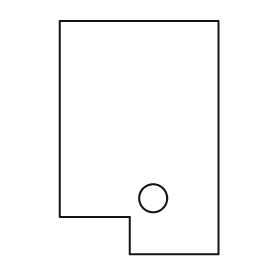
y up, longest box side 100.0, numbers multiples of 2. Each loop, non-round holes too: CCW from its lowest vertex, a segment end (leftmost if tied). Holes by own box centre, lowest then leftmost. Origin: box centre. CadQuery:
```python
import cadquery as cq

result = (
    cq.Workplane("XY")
    .moveTo(-4.0, -50.0)
    .lineTo(34.0, -50.0)
    .lineTo(34.0, 50.0)
    .lineTo(-34.0, 50.0)
    .lineTo(-34.0, -34.0)
    .lineTo(-4.0, -34.0)
    .close()
    .moveTo(6.0, -26.0)
    .circle(6.0)
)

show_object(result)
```